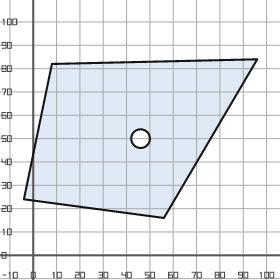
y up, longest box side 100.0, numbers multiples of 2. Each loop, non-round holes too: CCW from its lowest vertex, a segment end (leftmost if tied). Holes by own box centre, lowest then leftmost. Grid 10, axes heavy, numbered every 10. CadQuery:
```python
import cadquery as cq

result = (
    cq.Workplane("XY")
    .moveTo(56.0, 16.0)
    .lineTo(96.0, 84.0)
    .lineTo(8.0, 82.0)
    .lineTo(-4.0, 24.0)
    .close()
    .moveTo(46.0, 50.0)
    .circle(4.0)
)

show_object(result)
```